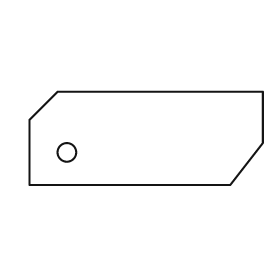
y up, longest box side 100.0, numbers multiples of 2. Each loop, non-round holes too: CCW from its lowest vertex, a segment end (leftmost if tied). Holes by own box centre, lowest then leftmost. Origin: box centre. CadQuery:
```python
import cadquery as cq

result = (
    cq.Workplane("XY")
    .moveTo(-50.0, -20.0)
    .lineTo(36.0, -20.0)
    .lineTo(50.0, -2.0)
    .lineTo(50.0, 20.0)
    .lineTo(-38.0, 20.0)
    .lineTo(-50.0, 8.0)
    .close()
    .moveTo(-34.0, -6.0)
    .circle(4.0)
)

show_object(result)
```